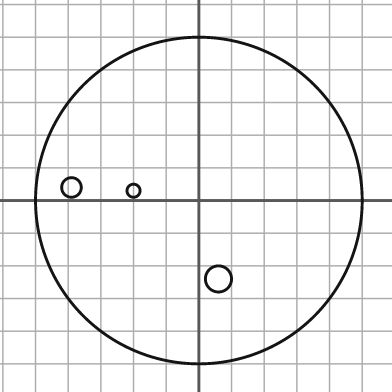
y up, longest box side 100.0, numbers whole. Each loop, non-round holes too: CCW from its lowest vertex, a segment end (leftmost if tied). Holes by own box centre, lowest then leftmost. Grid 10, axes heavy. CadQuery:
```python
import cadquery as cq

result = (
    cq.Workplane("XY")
    .moveTo(0.0, 0.0)
    .circle(50.0)
    .moveTo(6.0, -24.0)
    .circle(4.0)
    .moveTo(-20.0, 3.0)
    .circle(2.0)
    .moveTo(-39.0, 4.0)
    .circle(3.0)
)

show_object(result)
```